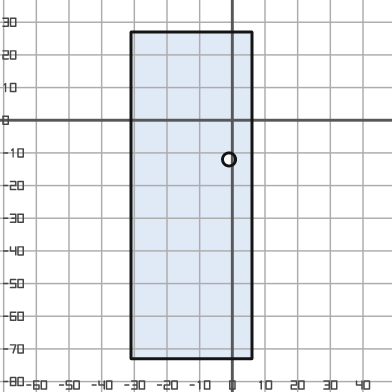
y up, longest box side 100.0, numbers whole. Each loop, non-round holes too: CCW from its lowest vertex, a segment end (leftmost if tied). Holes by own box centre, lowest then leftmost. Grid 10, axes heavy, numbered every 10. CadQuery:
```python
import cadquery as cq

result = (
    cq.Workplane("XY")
    .moveTo(-31.0, -73.0)
    .lineTo(6.0, -73.0)
    .lineTo(6.0, 27.0)
    .lineTo(-31.0, 27.0)
    .close()
    .moveTo(-1.0, -12.0)
    .circle(2.0)
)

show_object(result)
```